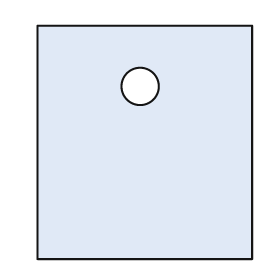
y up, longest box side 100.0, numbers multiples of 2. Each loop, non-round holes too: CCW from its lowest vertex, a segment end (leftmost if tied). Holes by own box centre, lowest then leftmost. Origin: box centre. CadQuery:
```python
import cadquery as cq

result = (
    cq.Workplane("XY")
    .moveTo(-46.0, -50.0)
    .lineTo(46.0, -50.0)
    .lineTo(46.0, 50.0)
    .lineTo(-46.0, 50.0)
    .close()
    .moveTo(-2.0, 24.0)
    .circle(8.0)
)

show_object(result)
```